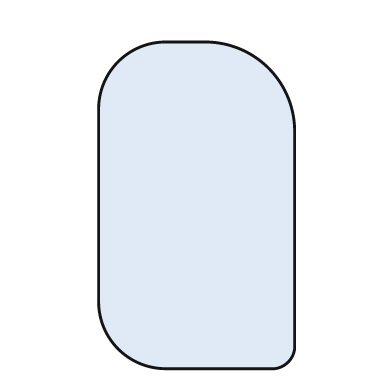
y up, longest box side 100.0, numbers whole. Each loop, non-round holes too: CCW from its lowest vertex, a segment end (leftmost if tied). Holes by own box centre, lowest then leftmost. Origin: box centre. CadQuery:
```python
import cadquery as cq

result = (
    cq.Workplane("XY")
    .moveTo(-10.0, -50.0)
    .lineTo(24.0, -50.0)
    .threePointArc((28.0, -48.0), (30.0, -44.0))
    .lineTo(30.0, 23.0)
    .threePointArc((22.0, 42.0), (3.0, 50.0))
    .lineTo(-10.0, 50.0)
    .threePointArc((-24.0, 44.0), (-30.0, 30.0))
    .lineTo(-30.0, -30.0)
    .threePointArc((-24.0, -44.0), (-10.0, -50.0))
    .close()
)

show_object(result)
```